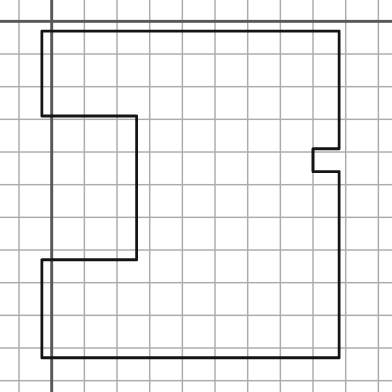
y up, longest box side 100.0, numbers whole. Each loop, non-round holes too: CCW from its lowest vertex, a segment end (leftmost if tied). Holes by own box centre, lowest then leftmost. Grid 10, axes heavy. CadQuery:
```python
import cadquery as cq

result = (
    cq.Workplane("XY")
    .moveTo(-3.0, -103.0)
    .lineTo(88.0, -103.0)
    .lineTo(88.0, -46.0)
    .lineTo(80.0, -46.0)
    .lineTo(80.0, -39.0)
    .lineTo(88.0, -39.0)
    .lineTo(88.0, -3.0)
    .lineTo(-3.0, -3.0)
    .lineTo(-3.0, -29.0)
    .lineTo(26.0, -29.0)
    .lineTo(26.0, -73.0)
    .lineTo(-3.0, -73.0)
    .close()
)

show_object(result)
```